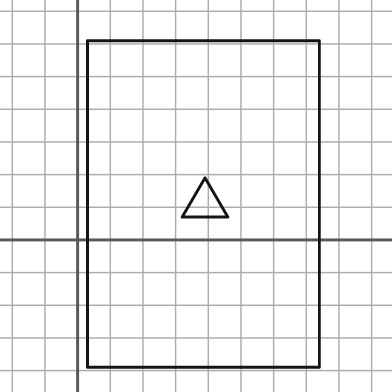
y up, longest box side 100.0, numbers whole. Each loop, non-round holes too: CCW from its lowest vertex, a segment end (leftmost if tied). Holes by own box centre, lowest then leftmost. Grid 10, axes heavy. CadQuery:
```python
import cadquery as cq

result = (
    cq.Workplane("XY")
    .moveTo(3.0, -39.0)
    .lineTo(74.0, -39.0)
    .lineTo(74.0, 61.0)
    .lineTo(3.0, 61.0)
    .close()
    .moveTo(32.0, 7.0)
    .lineTo(46.0, 7.0)
    .lineTo(39.0, 19.0)
    .close()
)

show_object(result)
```